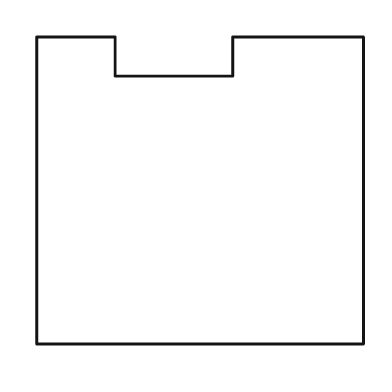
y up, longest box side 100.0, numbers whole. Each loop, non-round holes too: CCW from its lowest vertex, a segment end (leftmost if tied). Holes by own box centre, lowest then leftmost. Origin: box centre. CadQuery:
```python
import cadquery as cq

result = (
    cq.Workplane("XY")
    .moveTo(-50.0, -47.0)
    .lineTo(50.0, -47.0)
    .lineTo(50.0, 47.0)
    .lineTo(10.0, 47.0)
    .lineTo(10.0, 35.0)
    .lineTo(-26.0, 35.0)
    .lineTo(-26.0, 47.0)
    .lineTo(-50.0, 47.0)
    .close()
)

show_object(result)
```